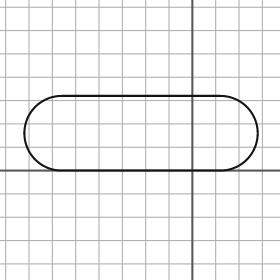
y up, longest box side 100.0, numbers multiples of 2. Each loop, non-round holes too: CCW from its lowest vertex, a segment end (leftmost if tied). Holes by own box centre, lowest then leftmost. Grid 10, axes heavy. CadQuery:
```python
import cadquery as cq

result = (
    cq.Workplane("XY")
    .moveTo(-56.0, 0.0)
    .lineTo(12.0, 0.0)
    .threePointArc((28.0, 16.0), (12.0, 32.0))
    .lineTo(-56.0, 32.0)
    .threePointArc((-72.0, 16.0), (-56.0, 0.0))
    .close()
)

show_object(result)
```